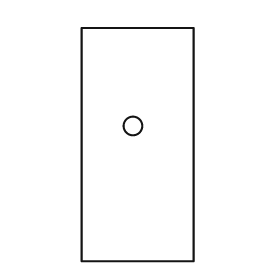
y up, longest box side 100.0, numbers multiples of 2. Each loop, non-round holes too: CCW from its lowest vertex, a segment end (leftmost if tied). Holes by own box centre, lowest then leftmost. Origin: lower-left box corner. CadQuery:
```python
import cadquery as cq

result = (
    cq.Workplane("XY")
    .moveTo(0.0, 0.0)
    .lineTo(48.0, 0.0)
    .lineTo(48.0, 100.0)
    .lineTo(0.0, 100.0)
    .close()
    .moveTo(22.0, 58.0)
    .circle(4.0)
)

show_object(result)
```